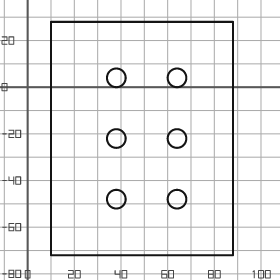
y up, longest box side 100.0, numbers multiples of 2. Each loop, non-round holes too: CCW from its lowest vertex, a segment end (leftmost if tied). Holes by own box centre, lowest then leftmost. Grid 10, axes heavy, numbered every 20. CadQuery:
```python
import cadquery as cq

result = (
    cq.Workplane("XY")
    .moveTo(10.0, -72.0)
    .lineTo(88.0, -72.0)
    .lineTo(88.0, 28.0)
    .lineTo(10.0, 28.0)
    .close()
    .moveTo(38.0, -48.0)
    .circle(4.0)
    .moveTo(64.0, -48.0)
    .circle(4.0)
    .moveTo(38.0, -22.0)
    .circle(4.0)
    .moveTo(64.0, -22.0)
    .circle(4.0)
    .moveTo(38.0, 4.0)
    .circle(4.0)
    .moveTo(64.0, 4.0)
    .circle(4.0)
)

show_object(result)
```